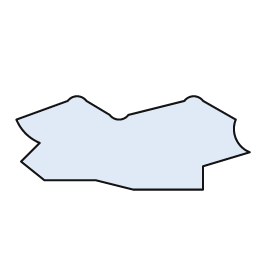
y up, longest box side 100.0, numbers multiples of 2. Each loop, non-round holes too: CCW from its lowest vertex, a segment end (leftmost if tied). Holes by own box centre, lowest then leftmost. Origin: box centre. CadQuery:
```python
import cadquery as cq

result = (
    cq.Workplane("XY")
    .moveTo(0.0, -20.0)
    .lineTo(30.0, -20.0)
    .lineTo(30.0, -10.0)
    .lineTo(50.0, -4.0)
    .threePointArc((44.0, 2.0), (44.0, 10.0))
    .lineTo(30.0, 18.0)
    .threePointArc((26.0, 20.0), (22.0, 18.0))
    .lineTo(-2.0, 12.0)
    .threePointArc((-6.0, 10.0), (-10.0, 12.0))
    .lineTo(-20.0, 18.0)
    .threePointArc((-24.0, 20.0), (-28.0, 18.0))
    .lineTo(-50.0, 10.0)
    .threePointArc((-46.0, 4.0), (-40.0, 0.0))
    .lineTo(-48.0, -8.0)
    .lineTo(-38.0, -16.0)
    .lineTo(-16.0, -16.0)
    .close()
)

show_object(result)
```